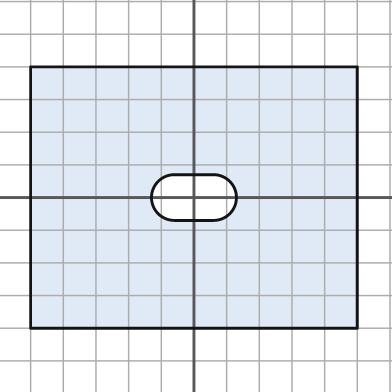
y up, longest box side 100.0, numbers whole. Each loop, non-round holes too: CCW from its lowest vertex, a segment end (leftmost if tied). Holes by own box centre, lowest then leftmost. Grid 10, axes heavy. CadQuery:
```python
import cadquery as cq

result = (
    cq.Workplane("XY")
    .moveTo(-50.0, -40.0)
    .lineTo(50.0, -40.0)
    .lineTo(50.0, 40.0)
    .lineTo(-50.0, 40.0)
    .close()
    .moveTo(-6.0, -7.0)
    .lineTo(6.0, -7.0)
    .threePointArc((13.0, 0.0), (6.0, 7.0))
    .lineTo(-6.0, 7.0)
    .threePointArc((-13.0, 0.0), (-6.0, -7.0))
    .close()
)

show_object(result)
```